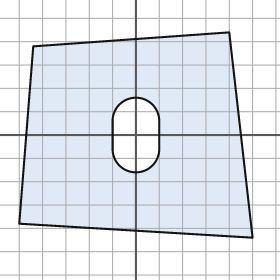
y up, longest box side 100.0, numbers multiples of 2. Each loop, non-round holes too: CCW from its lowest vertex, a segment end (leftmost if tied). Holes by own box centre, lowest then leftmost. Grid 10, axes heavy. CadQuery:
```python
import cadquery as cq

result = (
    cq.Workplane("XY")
    .moveTo(50.0, -44.0)
    .lineTo(40.0, 44.0)
    .lineTo(-44.0, 38.0)
    .lineTo(-50.0, -38.0)
    .close()
    .moveTo(-10.0, -6.0)
    .threePointArc((0.0, -16.0), (10.0, -6.0))
    .lineTo(10.0, 6.0)
    .threePointArc((0.0, 16.0), (-10.0, 6.0))
    .close()
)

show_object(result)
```